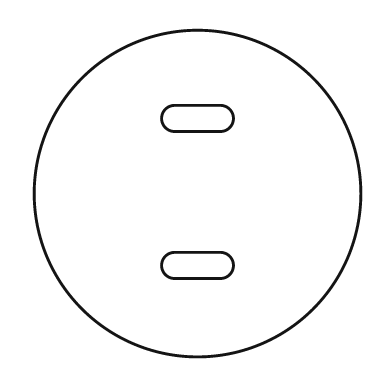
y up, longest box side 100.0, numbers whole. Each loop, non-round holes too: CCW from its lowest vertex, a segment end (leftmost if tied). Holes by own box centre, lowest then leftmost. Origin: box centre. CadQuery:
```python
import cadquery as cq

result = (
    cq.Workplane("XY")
    .moveTo(0.0, 0.0)
    .circle(50.0)
    .moveTo(-7.0, -26.0)
    .lineTo(7.0, -26.0)
    .threePointArc((11.0, -22.0), (7.0, -18.0))
    .lineTo(-7.0, -18.0)
    .threePointArc((-11.0, -22.0), (-7.0, -26.0))
    .close()
    .moveTo(-7.0, 19.0)
    .lineTo(7.0, 19.0)
    .threePointArc((11.0, 23.0), (7.0, 27.0))
    .lineTo(-7.0, 27.0)
    .threePointArc((-11.0, 23.0), (-7.0, 19.0))
    .close()
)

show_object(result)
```